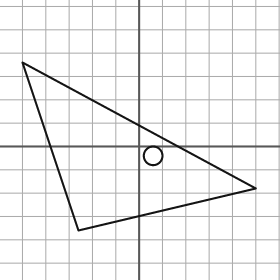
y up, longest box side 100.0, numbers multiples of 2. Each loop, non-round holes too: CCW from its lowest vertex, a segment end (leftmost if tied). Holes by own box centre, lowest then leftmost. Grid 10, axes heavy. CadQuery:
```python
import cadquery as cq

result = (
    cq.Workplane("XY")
    .moveTo(-26.0, -36.0)
    .lineTo(50.0, -18.0)
    .lineTo(-50.0, 36.0)
    .close()
    .moveTo(6.0, -4.0)
    .circle(4.0)
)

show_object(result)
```